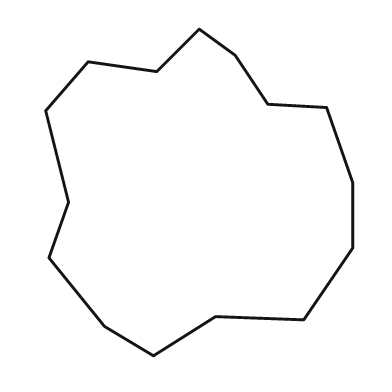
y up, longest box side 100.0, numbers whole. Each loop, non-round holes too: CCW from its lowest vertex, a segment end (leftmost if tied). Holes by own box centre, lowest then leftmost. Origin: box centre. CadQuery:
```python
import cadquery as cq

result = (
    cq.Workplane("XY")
    .moveTo(-14.0, -50.0)
    .lineTo(5.0, -38.0)
    .lineTo(32.0, -39.0)
    .lineTo(47.0, -17.0)
    .lineTo(47.0, 3.0)
    .lineTo(39.0, 26.0)
    .lineTo(21.0, 27.0)
    .lineTo(11.0, 42.0)
    .lineTo(0.0, 50.0)
    .lineTo(-13.0, 37.0)
    .lineTo(-34.0, 40.0)
    .lineTo(-47.0, 25.0)
    .lineTo(-40.0, -3.0)
    .lineTo(-46.0, -20.0)
    .lineTo(-29.0, -41.0)
    .close()
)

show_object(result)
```